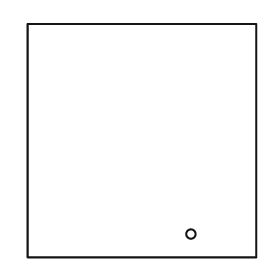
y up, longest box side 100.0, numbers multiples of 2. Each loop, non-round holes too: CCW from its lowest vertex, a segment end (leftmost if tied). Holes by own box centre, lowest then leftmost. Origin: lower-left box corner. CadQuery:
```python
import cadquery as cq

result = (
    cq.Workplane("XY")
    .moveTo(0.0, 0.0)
    .lineTo(98.0, 0.0)
    .lineTo(98.0, 100.0)
    .lineTo(0.0, 100.0)
    .close()
    .moveTo(70.0, 10.0)
    .circle(2.0)
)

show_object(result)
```